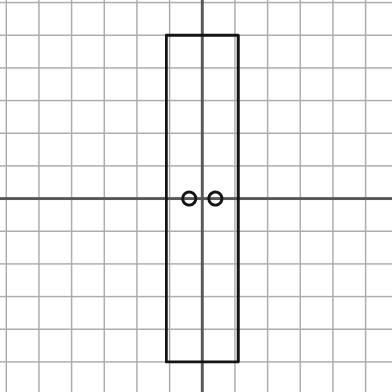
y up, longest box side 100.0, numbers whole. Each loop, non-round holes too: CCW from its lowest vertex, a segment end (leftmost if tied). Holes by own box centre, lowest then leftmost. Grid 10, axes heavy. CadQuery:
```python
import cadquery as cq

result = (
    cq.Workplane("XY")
    .moveTo(-11.0, -50.0)
    .lineTo(11.0, -50.0)
    .lineTo(11.0, 50.0)
    .lineTo(-11.0, 50.0)
    .close()
    .moveTo(-4.0, 0.0)
    .circle(2.0)
    .moveTo(4.0, 0.0)
    .circle(2.0)
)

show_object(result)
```